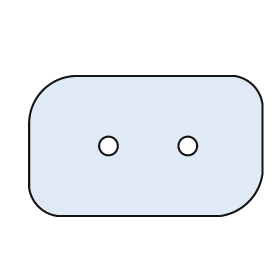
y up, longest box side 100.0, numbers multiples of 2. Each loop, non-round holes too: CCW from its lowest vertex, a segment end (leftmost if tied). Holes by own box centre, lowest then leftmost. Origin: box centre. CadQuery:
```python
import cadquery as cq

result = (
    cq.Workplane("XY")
    .moveTo(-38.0, -30.0)
    .lineTo(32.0, -30.0)
    .threePointArc((44.0, -24.0), (50.0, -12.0))
    .lineTo(50.0, 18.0)
    .threePointArc((46.0, 26.0), (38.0, 30.0))
    .lineTo(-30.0, 30.0)
    .threePointArc((-44.0, 24.0), (-50.0, 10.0))
    .lineTo(-50.0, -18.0)
    .threePointArc((-46.0, -26.0), (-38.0, -30.0))
    .close()
    .moveTo(-16.0, 0.0)
    .circle(4.0)
    .moveTo(18.0, 0.0)
    .circle(4.0)
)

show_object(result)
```